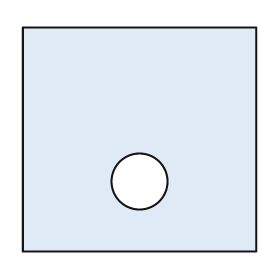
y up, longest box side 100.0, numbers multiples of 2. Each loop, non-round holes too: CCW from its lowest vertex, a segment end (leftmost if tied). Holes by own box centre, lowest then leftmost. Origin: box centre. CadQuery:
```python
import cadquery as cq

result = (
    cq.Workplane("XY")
    .moveTo(-50.0, -48.0)
    .lineTo(50.0, -48.0)
    .lineTo(50.0, 48.0)
    .lineTo(-50.0, 48.0)
    .close()
    .moveTo(0.0, -18.0)
    .circle(12.0)
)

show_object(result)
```